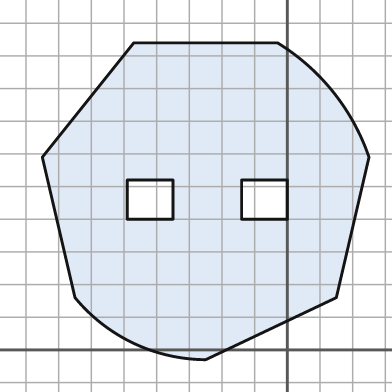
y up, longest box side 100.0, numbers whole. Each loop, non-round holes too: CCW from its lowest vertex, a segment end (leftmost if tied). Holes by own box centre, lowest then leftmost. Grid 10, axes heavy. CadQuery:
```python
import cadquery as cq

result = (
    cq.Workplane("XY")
    .moveTo(-25.0, -3.0)
    .lineTo(15.0, 16.0)
    .lineTo(25.0, 59.0)
    .threePointArc((14.0, 79.0), (-3.0, 94.0))
    .lineTo(-47.0, 94.0)
    .lineTo(-75.0, 59.0)
    .lineTo(-65.0, 16.0)
    .threePointArc((-47.0, 2.0), (-25.0, -3.0))
    .close()
    .moveTo(-49.0, 40.0)
    .lineTo(-35.0, 40.0)
    .lineTo(-35.0, 52.0)
    .lineTo(-49.0, 52.0)
    .close()
    .moveTo(-14.0, 40.0)
    .lineTo(0.0, 40.0)
    .lineTo(0.0, 52.0)
    .lineTo(-14.0, 52.0)
    .close()
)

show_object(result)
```